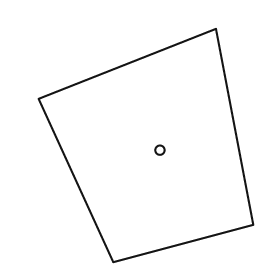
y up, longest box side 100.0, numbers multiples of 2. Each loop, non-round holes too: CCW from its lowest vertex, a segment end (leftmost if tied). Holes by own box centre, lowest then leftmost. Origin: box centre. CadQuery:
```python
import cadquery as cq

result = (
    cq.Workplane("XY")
    .moveTo(-14.0, -50.0)
    .lineTo(46.0, -34.0)
    .lineTo(30.0, 50.0)
    .lineTo(-46.0, 20.0)
    .close()
    .moveTo(6.0, -2.0)
    .circle(2.0)
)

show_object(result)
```